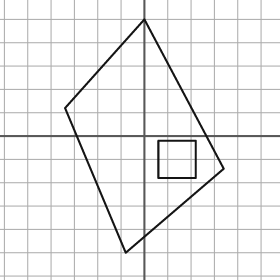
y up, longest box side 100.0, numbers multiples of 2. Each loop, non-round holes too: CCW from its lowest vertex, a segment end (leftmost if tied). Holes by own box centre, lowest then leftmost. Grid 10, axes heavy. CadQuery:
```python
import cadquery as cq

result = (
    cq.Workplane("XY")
    .moveTo(-8.0, -50.0)
    .lineTo(34.0, -14.0)
    .lineTo(0.0, 50.0)
    .lineTo(-34.0, 12.0)
    .close()
    .moveTo(6.0, -18.0)
    .lineTo(22.0, -18.0)
    .lineTo(22.0, -2.0)
    .lineTo(6.0, -2.0)
    .close()
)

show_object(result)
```